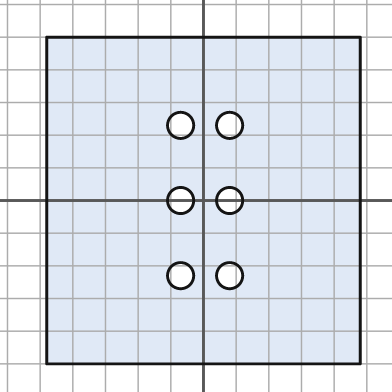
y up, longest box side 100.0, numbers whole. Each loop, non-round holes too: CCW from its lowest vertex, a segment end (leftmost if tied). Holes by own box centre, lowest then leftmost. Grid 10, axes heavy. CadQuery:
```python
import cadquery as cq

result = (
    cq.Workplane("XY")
    .moveTo(-48.0, -50.0)
    .lineTo(48.0, -50.0)
    .lineTo(48.0, 50.0)
    .lineTo(-48.0, 50.0)
    .close()
    .moveTo(-7.0, -23.0)
    .circle(4.0)
    .moveTo(8.0, -23.0)
    .circle(4.0)
    .moveTo(-7.0, 0.0)
    .circle(4.0)
    .moveTo(8.0, 0.0)
    .circle(4.0)
    .moveTo(-7.0, 23.0)
    .circle(4.0)
    .moveTo(8.0, 23.0)
    .circle(4.0)
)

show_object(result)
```